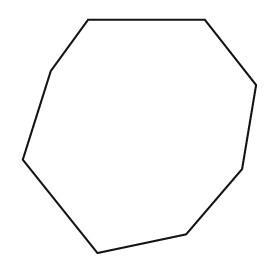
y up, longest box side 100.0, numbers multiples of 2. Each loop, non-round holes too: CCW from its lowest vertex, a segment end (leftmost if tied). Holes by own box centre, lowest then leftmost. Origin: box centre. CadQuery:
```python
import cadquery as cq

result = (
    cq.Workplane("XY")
    .moveTo(-18.0, -50.0)
    .lineTo(20.0, -42.0)
    .lineTo(44.0, -14.0)
    .lineTo(50.0, 22.0)
    .lineTo(28.0, 50.0)
    .lineTo(-22.0, 50.0)
    .lineTo(-38.0, 28.0)
    .lineTo(-50.0, -10.0)
    .close()
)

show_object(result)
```